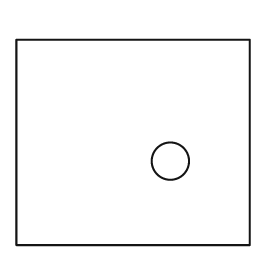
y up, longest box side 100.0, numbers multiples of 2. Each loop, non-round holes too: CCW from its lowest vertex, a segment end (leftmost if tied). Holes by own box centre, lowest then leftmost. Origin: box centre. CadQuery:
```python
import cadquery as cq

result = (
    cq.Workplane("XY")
    .moveTo(-50.0, -44.0)
    .lineTo(50.0, -44.0)
    .lineTo(50.0, 44.0)
    .lineTo(-50.0, 44.0)
    .close()
    .moveTo(16.0, -8.0)
    .circle(8.0)
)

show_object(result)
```